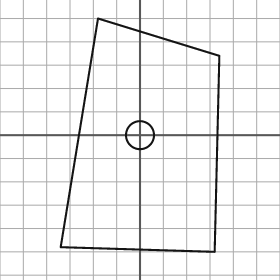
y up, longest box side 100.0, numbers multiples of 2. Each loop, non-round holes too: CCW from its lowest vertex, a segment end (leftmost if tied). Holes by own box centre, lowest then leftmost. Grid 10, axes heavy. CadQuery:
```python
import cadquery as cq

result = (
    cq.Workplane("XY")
    .moveTo(32.0, -50.0)
    .lineTo(34.0, 34.0)
    .lineTo(-18.0, 50.0)
    .lineTo(-34.0, -48.0)
    .close()
    .moveTo(0.0, 0.0)
    .circle(6.0)
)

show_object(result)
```